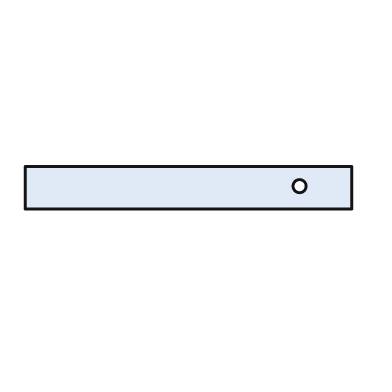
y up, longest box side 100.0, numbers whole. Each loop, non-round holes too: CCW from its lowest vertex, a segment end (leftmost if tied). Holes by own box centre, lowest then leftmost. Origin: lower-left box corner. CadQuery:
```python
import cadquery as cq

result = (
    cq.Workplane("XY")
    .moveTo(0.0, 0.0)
    .lineTo(100.0, 0.0)
    .lineTo(100.0, 13.0)
    .lineTo(0.0, 13.0)
    .close()
    .moveTo(84.0, 7.0)
    .circle(2.0)
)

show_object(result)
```